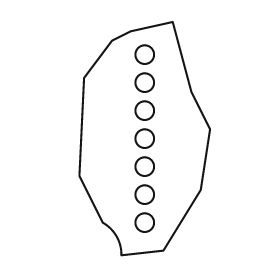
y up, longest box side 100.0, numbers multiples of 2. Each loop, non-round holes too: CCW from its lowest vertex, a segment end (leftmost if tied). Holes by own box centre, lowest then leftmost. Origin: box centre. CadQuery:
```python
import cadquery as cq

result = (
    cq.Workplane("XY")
    .moveTo(-10.0, -50.0)
    .lineTo(8.0, -48.0)
    .lineTo(24.0, -22.0)
    .lineTo(28.0, 4.0)
    .lineTo(20.0, 20.0)
    .lineTo(12.0, 50.0)
    .lineTo(-6.0, 46.0)
    .lineTo(-14.0, 42.0)
    .lineTo(-26.0, 26.0)
    .lineTo(-28.0, -16.0)
    .lineTo(-18.0, -36.0)
    .threePointArc((-12.0, -42.0), (-10.0, -50.0))
    .close()
    .moveTo(0.0, -36.0)
    .circle(4.0)
    .moveTo(0.0, -24.0)
    .circle(4.0)
    .moveTo(0.0, -12.0)
    .circle(4.0)
    .moveTo(0.0, 0.0)
    .circle(4.0)
    .moveTo(0.0, 12.0)
    .circle(4.0)
    .moveTo(0.0, 24.0)
    .circle(4.0)
    .moveTo(0.0, 36.0)
    .circle(4.0)
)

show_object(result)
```